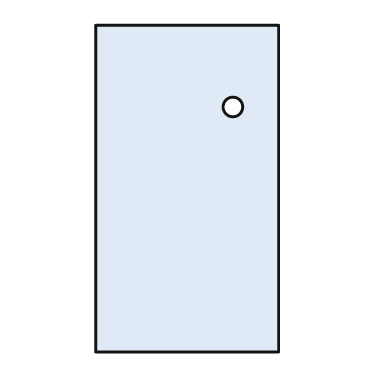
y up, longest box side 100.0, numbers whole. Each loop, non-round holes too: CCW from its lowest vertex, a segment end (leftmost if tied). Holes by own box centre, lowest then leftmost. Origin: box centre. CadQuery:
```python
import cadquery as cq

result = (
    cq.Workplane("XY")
    .moveTo(-28.0, -50.0)
    .lineTo(28.0, -50.0)
    .lineTo(28.0, 50.0)
    .lineTo(-28.0, 50.0)
    .close()
    .moveTo(14.0, 25.0)
    .circle(3.0)
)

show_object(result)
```